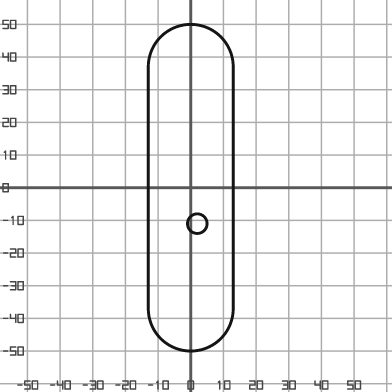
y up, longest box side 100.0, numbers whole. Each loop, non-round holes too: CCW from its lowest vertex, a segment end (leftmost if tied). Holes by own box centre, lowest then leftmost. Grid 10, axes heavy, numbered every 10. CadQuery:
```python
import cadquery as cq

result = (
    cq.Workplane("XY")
    .moveTo(-13.0, -37.0)
    .threePointArc((0.0, -50.0), (13.0, -37.0))
    .lineTo(13.0, 37.0)
    .threePointArc((0.0, 50.0), (-13.0, 37.0))
    .close()
    .moveTo(2.0, -11.0)
    .circle(3.0)
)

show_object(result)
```